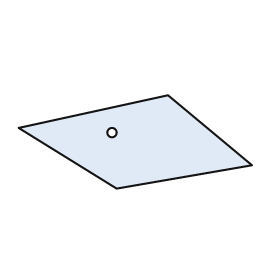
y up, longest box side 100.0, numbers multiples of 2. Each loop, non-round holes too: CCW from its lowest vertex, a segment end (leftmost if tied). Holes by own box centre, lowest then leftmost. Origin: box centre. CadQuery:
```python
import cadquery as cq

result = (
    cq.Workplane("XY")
    .moveTo(-8.0, -20.0)
    .lineTo(50.0, -10.0)
    .lineTo(14.0, 20.0)
    .lineTo(-50.0, 6.0)
    .close()
    .moveTo(-10.0, 4.0)
    .circle(2.0)
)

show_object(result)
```